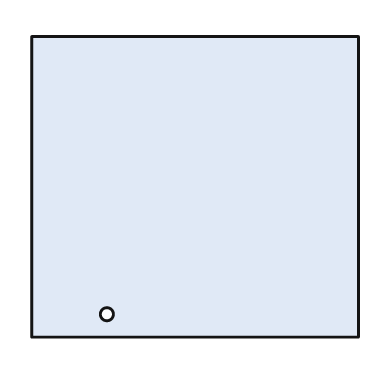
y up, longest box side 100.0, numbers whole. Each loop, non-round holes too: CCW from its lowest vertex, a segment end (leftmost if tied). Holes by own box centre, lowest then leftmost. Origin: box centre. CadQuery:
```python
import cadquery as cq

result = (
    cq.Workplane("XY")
    .moveTo(-50.0, -46.0)
    .lineTo(50.0, -46.0)
    .lineTo(50.0, 46.0)
    .lineTo(-50.0, 46.0)
    .close()
    .moveTo(-27.0, -39.0)
    .circle(2.0)
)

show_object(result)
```